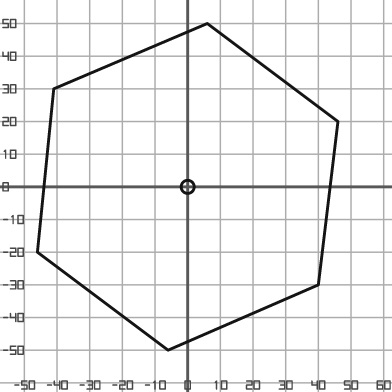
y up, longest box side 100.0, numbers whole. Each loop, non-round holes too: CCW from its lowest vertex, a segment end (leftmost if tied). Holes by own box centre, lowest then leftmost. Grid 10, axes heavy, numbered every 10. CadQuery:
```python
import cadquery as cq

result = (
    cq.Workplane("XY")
    .moveTo(-6.0, -50.0)
    .lineTo(40.0, -30.0)
    .lineTo(46.0, 20.0)
    .lineTo(6.0, 50.0)
    .lineTo(-41.0, 30.0)
    .lineTo(-46.0, -20.0)
    .close()
    .moveTo(0.0, 0.0)
    .circle(2.0)
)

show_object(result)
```